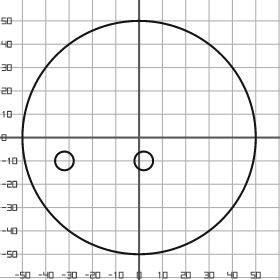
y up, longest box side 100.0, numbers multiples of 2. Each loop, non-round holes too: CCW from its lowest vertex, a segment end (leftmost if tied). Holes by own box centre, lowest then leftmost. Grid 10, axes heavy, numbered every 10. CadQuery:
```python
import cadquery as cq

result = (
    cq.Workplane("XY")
    .moveTo(0.0, 0.0)
    .circle(50.0)
    .moveTo(-32.0, -10.0)
    .circle(4.0)
    .moveTo(2.0, -10.0)
    .circle(4.0)
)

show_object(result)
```